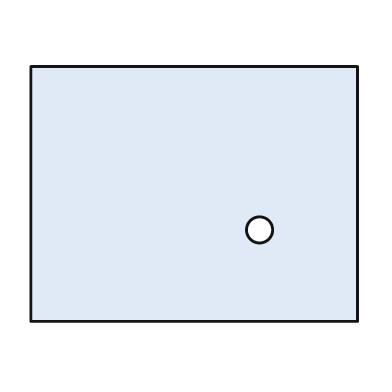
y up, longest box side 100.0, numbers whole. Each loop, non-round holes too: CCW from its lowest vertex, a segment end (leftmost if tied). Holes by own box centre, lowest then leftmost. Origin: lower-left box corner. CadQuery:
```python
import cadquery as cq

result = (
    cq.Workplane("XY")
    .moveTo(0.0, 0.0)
    .lineTo(100.0, 0.0)
    .lineTo(100.0, 78.0)
    .lineTo(0.0, 78.0)
    .close()
    .moveTo(70.0, 28.0)
    .circle(4.0)
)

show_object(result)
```